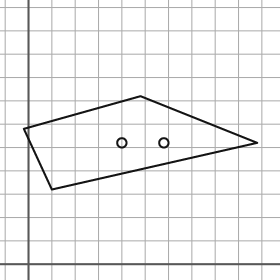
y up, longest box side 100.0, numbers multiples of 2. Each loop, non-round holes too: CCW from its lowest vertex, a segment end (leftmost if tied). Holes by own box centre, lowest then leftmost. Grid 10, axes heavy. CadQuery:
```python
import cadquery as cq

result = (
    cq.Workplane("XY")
    .moveTo(10.0, 32.0)
    .lineTo(98.0, 52.0)
    .lineTo(48.0, 72.0)
    .lineTo(-2.0, 58.0)
    .close()
    .moveTo(40.0, 52.0)
    .circle(2.0)
    .moveTo(58.0, 52.0)
    .circle(2.0)
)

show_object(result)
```